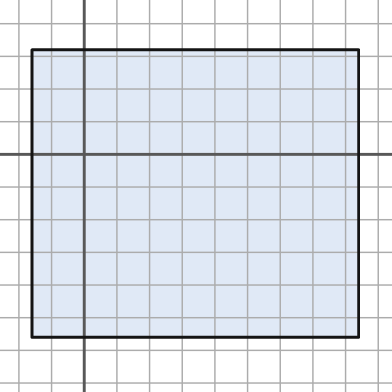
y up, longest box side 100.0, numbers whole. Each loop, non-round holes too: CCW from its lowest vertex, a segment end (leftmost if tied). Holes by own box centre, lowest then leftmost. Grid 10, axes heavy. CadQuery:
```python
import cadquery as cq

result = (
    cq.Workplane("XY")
    .moveTo(-16.0, -56.0)
    .lineTo(84.0, -56.0)
    .lineTo(84.0, 32.0)
    .lineTo(-16.0, 32.0)
    .close()
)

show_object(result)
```